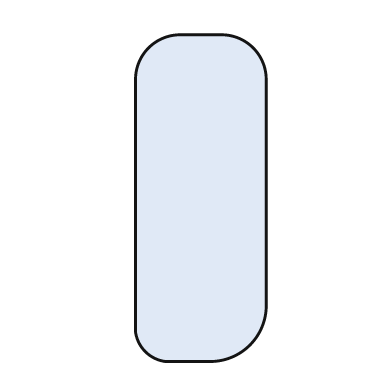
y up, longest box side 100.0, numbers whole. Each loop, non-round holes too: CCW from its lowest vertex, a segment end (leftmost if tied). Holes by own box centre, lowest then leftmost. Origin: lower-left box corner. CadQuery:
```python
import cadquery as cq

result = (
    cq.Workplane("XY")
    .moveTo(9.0, 0.0)
    .lineTo(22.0, 0.0)
    .threePointArc((35.0, 5.0), (40.0, 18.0))
    .lineTo(40.0, 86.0)
    .threePointArc((36.0, 96.0), (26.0, 100.0))
    .lineTo(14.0, 100.0)
    .threePointArc((4.0, 96.0), (0.0, 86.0))
    .lineTo(0.0, 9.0)
    .threePointArc((3.0, 3.0), (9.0, 0.0))
    .close()
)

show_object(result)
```